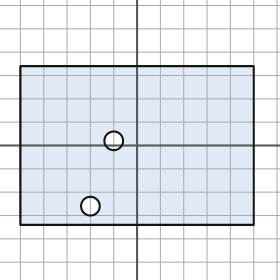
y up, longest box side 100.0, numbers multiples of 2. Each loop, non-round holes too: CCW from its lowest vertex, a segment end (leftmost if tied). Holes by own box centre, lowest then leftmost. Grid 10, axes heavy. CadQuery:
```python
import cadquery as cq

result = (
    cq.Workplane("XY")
    .moveTo(-50.0, -34.0)
    .lineTo(50.0, -34.0)
    .lineTo(50.0, 34.0)
    .lineTo(-50.0, 34.0)
    .close()
    .moveTo(-20.0, -26.0)
    .circle(4.0)
    .moveTo(-10.0, 2.0)
    .circle(4.0)
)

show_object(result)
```